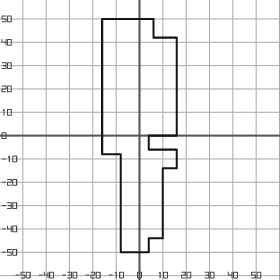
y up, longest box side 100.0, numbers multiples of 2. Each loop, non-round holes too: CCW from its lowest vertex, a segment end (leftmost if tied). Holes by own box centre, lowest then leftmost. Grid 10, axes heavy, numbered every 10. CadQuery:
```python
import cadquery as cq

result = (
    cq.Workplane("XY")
    .moveTo(-8.0, -50.0)
    .lineTo(4.0, -50.0)
    .lineTo(4.0, -44.0)
    .lineTo(10.0, -44.0)
    .lineTo(10.0, -14.0)
    .lineTo(16.0, -14.0)
    .lineTo(16.0, -6.0)
    .lineTo(4.0, -6.0)
    .lineTo(4.0, 0.0)
    .lineTo(16.0, 0.0)
    .lineTo(16.0, 42.0)
    .lineTo(6.0, 42.0)
    .lineTo(6.0, 50.0)
    .lineTo(-16.0, 50.0)
    .lineTo(-16.0, -8.0)
    .lineTo(-8.0, -8.0)
    .close()
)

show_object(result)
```